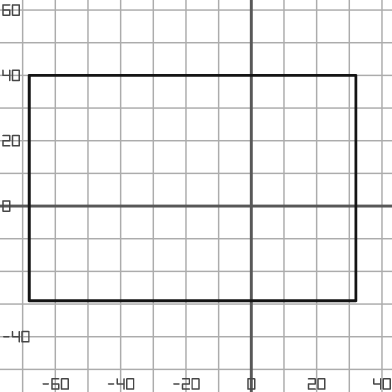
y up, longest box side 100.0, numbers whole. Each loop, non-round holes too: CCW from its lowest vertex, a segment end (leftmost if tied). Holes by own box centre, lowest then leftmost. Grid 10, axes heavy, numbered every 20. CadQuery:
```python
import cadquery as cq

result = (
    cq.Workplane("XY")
    .moveTo(-68.0, -29.0)
    .lineTo(32.0, -29.0)
    .lineTo(32.0, 40.0)
    .lineTo(-68.0, 40.0)
    .close()
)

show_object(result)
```